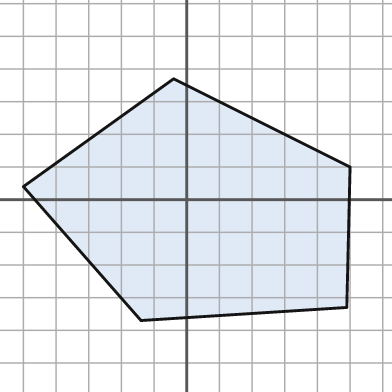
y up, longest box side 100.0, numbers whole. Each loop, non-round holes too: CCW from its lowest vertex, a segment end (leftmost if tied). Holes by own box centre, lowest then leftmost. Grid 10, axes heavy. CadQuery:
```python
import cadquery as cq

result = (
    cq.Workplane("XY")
    .moveTo(-14.0, -37.0)
    .lineTo(49.0, -33.0)
    .lineTo(50.0, 10.0)
    .lineTo(-4.0, 37.0)
    .lineTo(-50.0, 4.0)
    .close()
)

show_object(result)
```